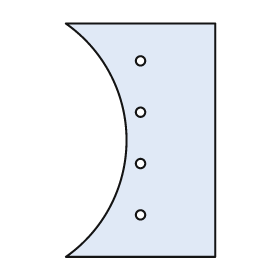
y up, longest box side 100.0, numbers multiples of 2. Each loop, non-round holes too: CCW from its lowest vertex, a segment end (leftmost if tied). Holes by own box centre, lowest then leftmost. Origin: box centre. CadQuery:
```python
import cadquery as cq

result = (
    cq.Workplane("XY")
    .moveTo(-32.0, -50.0)
    .lineTo(32.0, -50.0)
    .lineTo(32.0, 50.0)
    .lineTo(-32.0, 50.0)
    .threePointArc((-6.0, 0.0), (-32.0, -50.0))
    .close()
    .moveTo(0.0, -32.0)
    .circle(2.0)
    .moveTo(0.0, -10.0)
    .circle(2.0)
    .moveTo(0.0, 12.0)
    .circle(2.0)
    .moveTo(0.0, 34.0)
    .circle(2.0)
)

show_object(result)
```